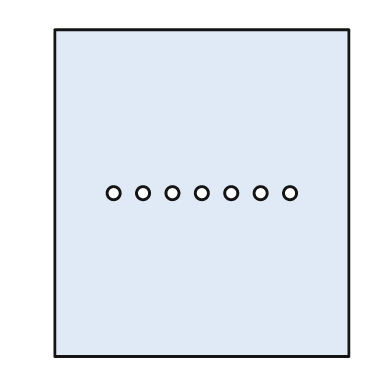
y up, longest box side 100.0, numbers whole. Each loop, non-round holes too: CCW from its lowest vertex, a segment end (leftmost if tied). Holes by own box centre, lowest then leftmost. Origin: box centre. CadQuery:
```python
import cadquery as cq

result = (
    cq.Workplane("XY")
    .moveTo(-45.0, -50.0)
    .lineTo(45.0, -50.0)
    .lineTo(45.0, 50.0)
    .lineTo(-45.0, 50.0)
    .close()
    .moveTo(-27.0, 0.0)
    .circle(2.0)
    .moveTo(-18.0, 0.0)
    .circle(2.0)
    .moveTo(-9.0, 0.0)
    .circle(2.0)
    .moveTo(0.0, 0.0)
    .circle(2.0)
    .moveTo(9.0, 0.0)
    .circle(2.0)
    .moveTo(18.0, 0.0)
    .circle(2.0)
    .moveTo(27.0, 0.0)
    .circle(2.0)
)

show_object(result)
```